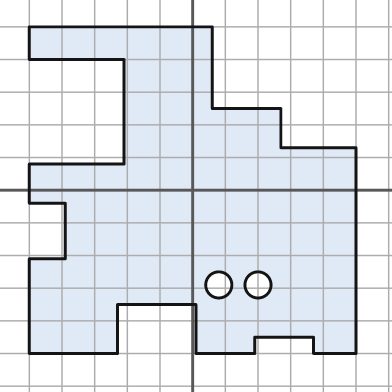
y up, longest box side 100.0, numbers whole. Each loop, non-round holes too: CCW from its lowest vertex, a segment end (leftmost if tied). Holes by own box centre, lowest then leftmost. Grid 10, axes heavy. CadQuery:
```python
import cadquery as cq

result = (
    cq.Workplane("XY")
    .moveTo(-50.0, -50.0)
    .lineTo(-23.0, -50.0)
    .lineTo(-23.0, -35.0)
    .lineTo(1.0, -35.0)
    .lineTo(1.0, -50.0)
    .lineTo(19.0, -50.0)
    .lineTo(19.0, -45.0)
    .lineTo(37.0, -45.0)
    .lineTo(37.0, -50.0)
    .lineTo(50.0, -50.0)
    .lineTo(50.0, 13.0)
    .lineTo(27.0, 13.0)
    .lineTo(27.0, 25.0)
    .lineTo(6.0, 25.0)
    .lineTo(6.0, 50.0)
    .lineTo(-50.0, 50.0)
    .lineTo(-50.0, 40.0)
    .lineTo(-21.0, 40.0)
    .lineTo(-21.0, 8.0)
    .lineTo(-50.0, 8.0)
    .lineTo(-50.0, -4.0)
    .lineTo(-39.0, -4.0)
    .lineTo(-39.0, -21.0)
    .lineTo(-50.0, -21.0)
    .close()
    .moveTo(8.0, -29.0)
    .circle(4.0)
    .moveTo(20.0, -29.0)
    .circle(4.0)
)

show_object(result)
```